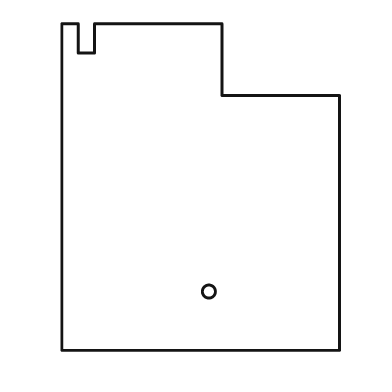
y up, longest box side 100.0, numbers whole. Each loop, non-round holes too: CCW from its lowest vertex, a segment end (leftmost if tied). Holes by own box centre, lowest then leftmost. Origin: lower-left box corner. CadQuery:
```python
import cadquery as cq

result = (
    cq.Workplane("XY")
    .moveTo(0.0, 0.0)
    .lineTo(85.0, 0.0)
    .lineTo(85.0, 78.0)
    .lineTo(49.0, 78.0)
    .lineTo(49.0, 100.0)
    .lineTo(10.0, 100.0)
    .lineTo(10.0, 91.0)
    .lineTo(5.0, 91.0)
    .lineTo(5.0, 100.0)
    .lineTo(0.0, 100.0)
    .close()
    .moveTo(45.0, 18.0)
    .circle(2.0)
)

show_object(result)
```